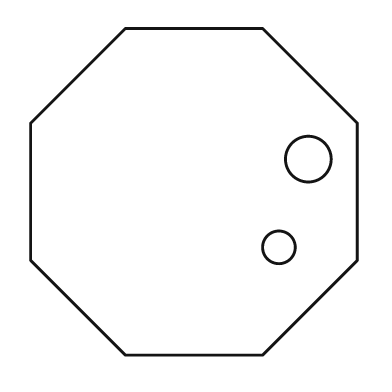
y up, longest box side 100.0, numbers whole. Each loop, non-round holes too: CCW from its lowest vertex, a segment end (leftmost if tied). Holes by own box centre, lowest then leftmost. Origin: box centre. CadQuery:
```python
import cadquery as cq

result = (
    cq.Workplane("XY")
    .moveTo(-21.0, -50.0)
    .lineTo(21.0, -50.0)
    .lineTo(50.0, -21.0)
    .lineTo(50.0, 21.0)
    .lineTo(21.0, 50.0)
    .lineTo(-21.0, 50.0)
    .lineTo(-50.0, 21.0)
    .lineTo(-50.0, -21.0)
    .close()
    .moveTo(26.0, -17.0)
    .circle(5.0)
    .moveTo(35.0, 10.0)
    .circle(7.0)
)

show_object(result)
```